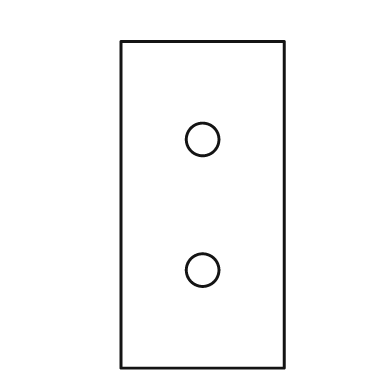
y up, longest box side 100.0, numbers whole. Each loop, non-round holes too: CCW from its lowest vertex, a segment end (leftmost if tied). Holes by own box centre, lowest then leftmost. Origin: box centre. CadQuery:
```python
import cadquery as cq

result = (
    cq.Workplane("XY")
    .moveTo(-25.0, -50.0)
    .lineTo(25.0, -50.0)
    .lineTo(25.0, 50.0)
    .lineTo(-25.0, 50.0)
    .close()
    .moveTo(0.0, -20.0)
    .circle(5.0)
    .moveTo(0.0, 20.0)
    .circle(5.0)
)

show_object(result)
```